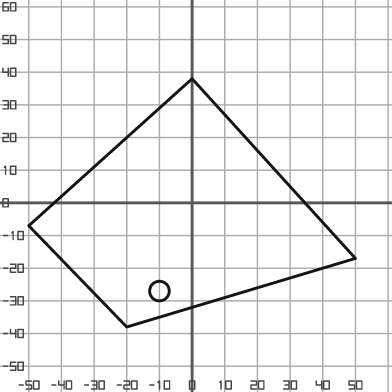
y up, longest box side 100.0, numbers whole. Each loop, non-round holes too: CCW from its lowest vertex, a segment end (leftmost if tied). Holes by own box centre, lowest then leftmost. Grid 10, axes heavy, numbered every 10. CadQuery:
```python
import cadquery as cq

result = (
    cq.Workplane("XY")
    .moveTo(-20.0, -38.0)
    .lineTo(50.0, -17.0)
    .lineTo(0.0, 38.0)
    .lineTo(-50.0, -7.0)
    .close()
    .moveTo(-10.0, -27.0)
    .circle(3.0)
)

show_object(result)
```